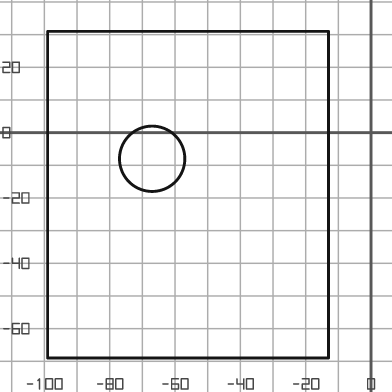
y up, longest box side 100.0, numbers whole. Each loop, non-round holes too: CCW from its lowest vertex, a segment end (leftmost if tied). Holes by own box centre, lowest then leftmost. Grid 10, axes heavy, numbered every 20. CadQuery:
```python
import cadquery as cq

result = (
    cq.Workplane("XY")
    .moveTo(-99.0, -69.0)
    .lineTo(-13.0, -69.0)
    .lineTo(-13.0, 31.0)
    .lineTo(-99.0, 31.0)
    .close()
    .moveTo(-67.0, -8.0)
    .circle(10.0)
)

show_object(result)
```